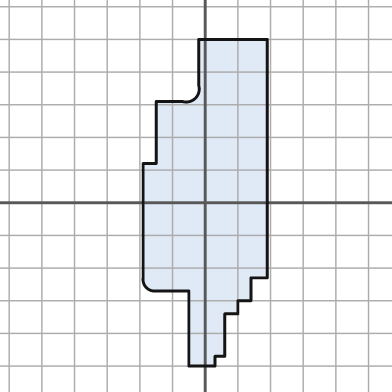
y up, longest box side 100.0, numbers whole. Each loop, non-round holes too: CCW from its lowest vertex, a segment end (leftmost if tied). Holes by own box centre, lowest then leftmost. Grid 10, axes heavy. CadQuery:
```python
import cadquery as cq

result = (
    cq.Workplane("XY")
    .moveTo(-5.0, -50.0)
    .lineTo(3.0, -50.0)
    .lineTo(3.0, -47.0)
    .lineTo(6.0, -47.0)
    .lineTo(6.0, -34.0)
    .lineTo(10.0, -34.0)
    .lineTo(10.0, -30.0)
    .lineTo(14.0, -30.0)
    .lineTo(14.0, -23.0)
    .lineTo(19.0, -23.0)
    .lineTo(19.0, 50.0)
    .lineTo(-2.0, 50.0)
    .lineTo(-2.0, 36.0)
    .threePointArc((-3.0, 32.0), (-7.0, 31.0))
    .lineTo(-15.0, 31.0)
    .lineTo(-15.0, 12.0)
    .lineTo(-19.0, 12.0)
    .lineTo(-19.0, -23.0)
    .threePointArc((-18.0, -26.0), (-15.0, -27.0))
    .lineTo(-5.0, -27.0)
    .close()
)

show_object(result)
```